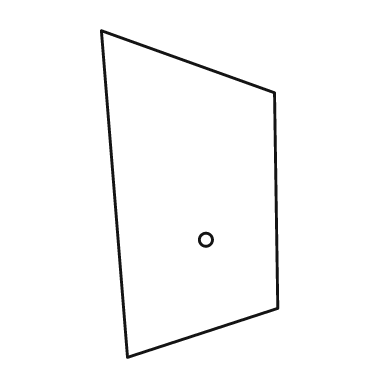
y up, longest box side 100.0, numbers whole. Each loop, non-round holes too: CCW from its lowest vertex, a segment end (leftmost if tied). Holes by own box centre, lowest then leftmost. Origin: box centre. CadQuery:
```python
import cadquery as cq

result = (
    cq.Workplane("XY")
    .moveTo(-19.0, -50.0)
    .lineTo(27.0, -35.0)
    .lineTo(26.0, 31.0)
    .lineTo(-27.0, 50.0)
    .close()
    .moveTo(5.0, -14.0)
    .circle(2.0)
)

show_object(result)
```